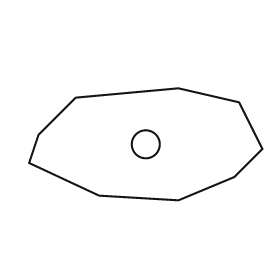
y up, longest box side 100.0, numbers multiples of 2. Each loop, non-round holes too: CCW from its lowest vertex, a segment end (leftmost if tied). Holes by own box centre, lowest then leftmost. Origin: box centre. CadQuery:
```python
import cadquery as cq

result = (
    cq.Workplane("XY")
    .moveTo(14.0, -24.0)
    .lineTo(38.0, -14.0)
    .lineTo(50.0, -2.0)
    .lineTo(40.0, 18.0)
    .lineTo(14.0, 24.0)
    .lineTo(-30.0, 20.0)
    .lineTo(-46.0, 4.0)
    .lineTo(-50.0, -8.0)
    .lineTo(-20.0, -22.0)
    .close()
    .moveTo(0.0, 0.0)
    .circle(6.0)
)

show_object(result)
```